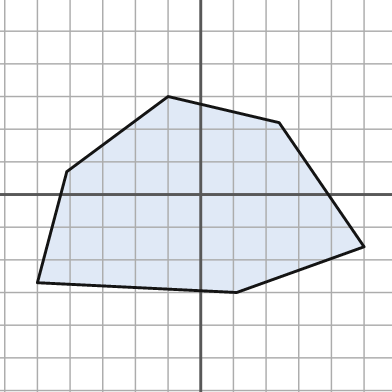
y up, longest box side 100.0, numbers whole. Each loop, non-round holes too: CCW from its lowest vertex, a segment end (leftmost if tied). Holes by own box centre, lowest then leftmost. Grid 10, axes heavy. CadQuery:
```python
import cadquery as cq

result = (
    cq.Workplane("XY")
    .moveTo(11.0, -30.0)
    .lineTo(50.0, -16.0)
    .lineTo(24.0, 22.0)
    .lineTo(-10.0, 30.0)
    .lineTo(-41.0, 7.0)
    .lineTo(-50.0, -27.0)
    .close()
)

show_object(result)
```